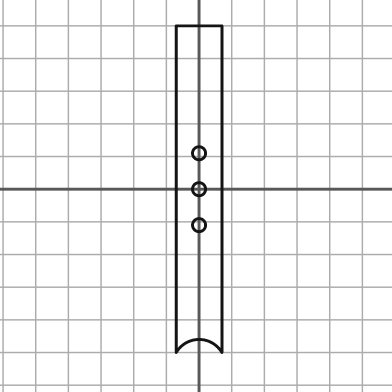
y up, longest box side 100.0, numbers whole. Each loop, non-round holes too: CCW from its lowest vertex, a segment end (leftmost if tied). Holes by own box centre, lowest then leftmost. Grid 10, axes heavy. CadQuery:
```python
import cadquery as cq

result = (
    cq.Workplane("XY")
    .moveTo(-7.0, -50.0)
    .threePointArc((0.0, -46.0), (7.0, -50.0))
    .lineTo(7.0, 50.0)
    .lineTo(-7.0, 50.0)
    .close()
    .moveTo(0.0, -11.0)
    .circle(2.0)
    .moveTo(0.0, 0.0)
    .circle(2.0)
    .moveTo(0.0, 11.0)
    .circle(2.0)
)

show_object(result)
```